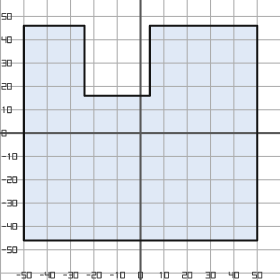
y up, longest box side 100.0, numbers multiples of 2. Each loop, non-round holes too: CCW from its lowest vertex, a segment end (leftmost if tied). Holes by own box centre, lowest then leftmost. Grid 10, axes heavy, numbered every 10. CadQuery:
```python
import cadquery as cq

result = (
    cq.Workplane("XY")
    .moveTo(-50.0, -46.0)
    .lineTo(50.0, -46.0)
    .lineTo(50.0, 46.0)
    .lineTo(4.0, 46.0)
    .lineTo(4.0, 16.0)
    .lineTo(-24.0, 16.0)
    .lineTo(-24.0, 46.0)
    .lineTo(-50.0, 46.0)
    .close()
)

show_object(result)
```